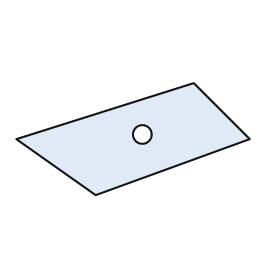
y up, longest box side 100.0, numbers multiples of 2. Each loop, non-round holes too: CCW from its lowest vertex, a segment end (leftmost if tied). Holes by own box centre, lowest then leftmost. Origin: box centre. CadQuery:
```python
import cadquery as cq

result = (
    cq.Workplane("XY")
    .moveTo(-16.0, -24.0)
    .lineTo(50.0, 0.0)
    .lineTo(26.0, 24.0)
    .lineTo(-50.0, 0.0)
    .close()
    .moveTo(4.0, 2.0)
    .circle(4.0)
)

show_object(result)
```